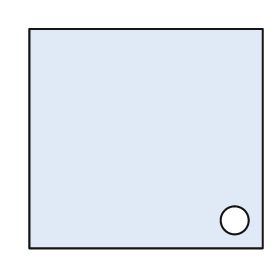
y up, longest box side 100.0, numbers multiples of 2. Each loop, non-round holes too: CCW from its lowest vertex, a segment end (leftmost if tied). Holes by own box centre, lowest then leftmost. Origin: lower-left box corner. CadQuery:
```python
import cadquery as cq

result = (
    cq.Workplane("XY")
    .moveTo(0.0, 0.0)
    .lineTo(100.0, 0.0)
    .lineTo(100.0, 94.0)
    .lineTo(0.0, 94.0)
    .close()
    .moveTo(88.0, 12.0)
    .circle(6.0)
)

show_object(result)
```